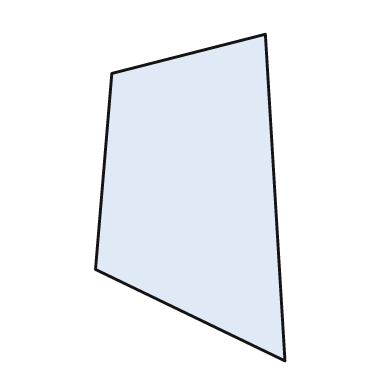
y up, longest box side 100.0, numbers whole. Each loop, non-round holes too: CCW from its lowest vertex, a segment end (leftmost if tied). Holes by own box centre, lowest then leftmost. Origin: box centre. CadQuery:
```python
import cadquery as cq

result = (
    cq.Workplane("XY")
    .moveTo(29.0, -50.0)
    .lineTo(23.0, 50.0)
    .lineTo(-24.0, 38.0)
    .lineTo(-29.0, -22.0)
    .close()
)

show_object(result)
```